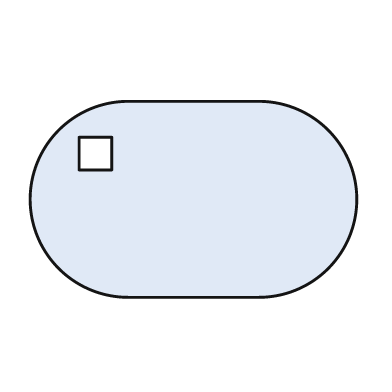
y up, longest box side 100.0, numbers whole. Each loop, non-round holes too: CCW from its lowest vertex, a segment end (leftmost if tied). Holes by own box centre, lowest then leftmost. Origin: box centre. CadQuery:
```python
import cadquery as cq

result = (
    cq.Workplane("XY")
    .moveTo(-20.0, -30.0)
    .lineTo(20.0, -30.0)
    .threePointArc((50.0, 0.0), (20.0, 30.0))
    .lineTo(-20.0, 30.0)
    .threePointArc((-50.0, 0.0), (-20.0, -30.0))
    .close()
    .moveTo(-35.0, 9.0)
    .lineTo(-25.0, 9.0)
    .lineTo(-25.0, 19.0)
    .lineTo(-35.0, 19.0)
    .close()
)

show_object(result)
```